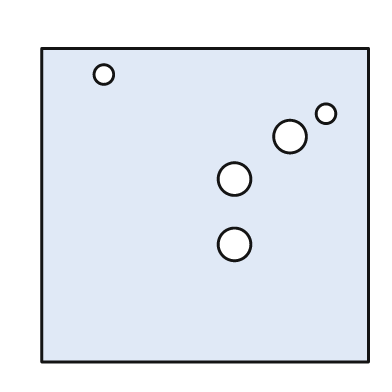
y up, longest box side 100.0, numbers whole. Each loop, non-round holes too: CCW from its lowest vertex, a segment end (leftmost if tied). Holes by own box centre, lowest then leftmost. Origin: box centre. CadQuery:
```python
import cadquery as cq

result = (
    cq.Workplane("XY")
    .moveTo(-50.0, -48.0)
    .lineTo(50.0, -48.0)
    .lineTo(50.0, 48.0)
    .lineTo(-50.0, 48.0)
    .close()
    .moveTo(9.0, -12.0)
    .circle(5.0)
    .moveTo(9.0, 8.0)
    .circle(5.0)
    .moveTo(26.0, 21.0)
    .circle(5.0)
    .moveTo(37.0, 28.0)
    .circle(3.0)
    .moveTo(-31.0, 40.0)
    .circle(3.0)
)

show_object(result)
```